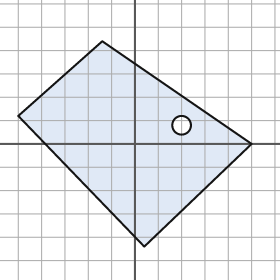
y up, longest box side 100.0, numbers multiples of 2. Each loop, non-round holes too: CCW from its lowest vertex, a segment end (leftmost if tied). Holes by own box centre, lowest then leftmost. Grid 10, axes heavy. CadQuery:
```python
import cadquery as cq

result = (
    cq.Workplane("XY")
    .moveTo(4.0, -44.0)
    .lineTo(50.0, 0.0)
    .lineTo(-14.0, 44.0)
    .lineTo(-50.0, 12.0)
    .close()
    .moveTo(20.0, 8.0)
    .circle(4.0)
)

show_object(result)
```